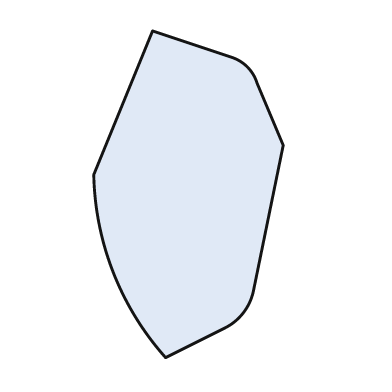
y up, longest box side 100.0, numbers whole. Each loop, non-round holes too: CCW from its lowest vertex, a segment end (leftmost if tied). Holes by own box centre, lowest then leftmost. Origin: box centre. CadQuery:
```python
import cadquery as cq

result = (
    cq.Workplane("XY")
    .moveTo(-7.0, -50.0)
    .lineTo(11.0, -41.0)
    .threePointArc((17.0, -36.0), (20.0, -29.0))
    .lineTo(29.0, 15.0)
    .lineTo(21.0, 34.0)
    .threePointArc((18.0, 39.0), (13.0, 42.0))
    .lineTo(-11.0, 50.0)
    .lineTo(-29.0, 6.0)
    .threePointArc((-23.0, -24.0), (-7.0, -50.0))
    .close()
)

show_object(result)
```